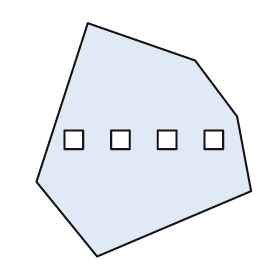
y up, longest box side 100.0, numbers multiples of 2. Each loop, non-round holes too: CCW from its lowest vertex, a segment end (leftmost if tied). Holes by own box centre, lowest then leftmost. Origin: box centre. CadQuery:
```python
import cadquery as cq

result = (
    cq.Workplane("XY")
    .moveTo(-20.0, -50.0)
    .lineTo(46.0, -22.0)
    .lineTo(40.0, 10.0)
    .lineTo(22.0, 34.0)
    .lineTo(-24.0, 50.0)
    .lineTo(-46.0, -18.0)
    .close()
    .moveTo(-34.0, -4.0)
    .lineTo(-26.0, -4.0)
    .lineTo(-26.0, 4.0)
    .lineTo(-34.0, 4.0)
    .close()
    .moveTo(-14.0, -4.0)
    .lineTo(-6.0, -4.0)
    .lineTo(-6.0, 4.0)
    .lineTo(-14.0, 4.0)
    .close()
    .moveTo(6.0, -4.0)
    .lineTo(14.0, -4.0)
    .lineTo(14.0, 4.0)
    .lineTo(6.0, 4.0)
    .close()
    .moveTo(26.0, -4.0)
    .lineTo(34.0, -4.0)
    .lineTo(34.0, 4.0)
    .lineTo(26.0, 4.0)
    .close()
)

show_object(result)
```